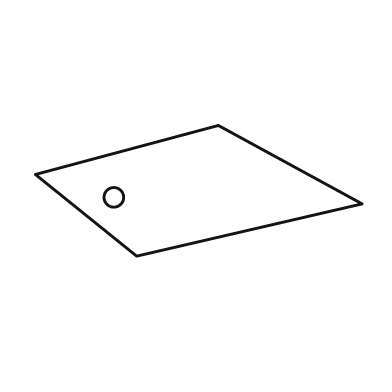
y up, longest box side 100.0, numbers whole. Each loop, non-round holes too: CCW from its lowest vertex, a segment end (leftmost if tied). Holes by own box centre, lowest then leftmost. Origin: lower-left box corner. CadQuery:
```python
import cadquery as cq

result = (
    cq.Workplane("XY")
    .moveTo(31.0, 0.0)
    .lineTo(100.0, 16.0)
    .lineTo(56.0, 40.0)
    .lineTo(0.0, 25.0)
    .close()
    .moveTo(24.0, 18.0)
    .circle(3.0)
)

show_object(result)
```